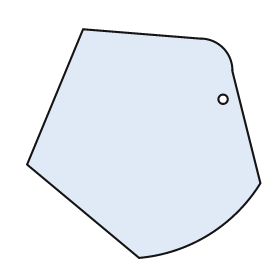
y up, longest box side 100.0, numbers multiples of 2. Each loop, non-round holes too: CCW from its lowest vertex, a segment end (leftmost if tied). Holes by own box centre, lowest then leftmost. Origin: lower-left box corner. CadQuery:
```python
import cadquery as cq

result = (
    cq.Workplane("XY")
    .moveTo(48.0, 0.0)
    .threePointArc((78.0, 10.0), (100.0, 32.0))
    .lineTo(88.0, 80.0)
    .threePointArc((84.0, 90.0), (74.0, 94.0))
    .lineTo(24.0, 98.0)
    .lineTo(0.0, 40.0)
    .close()
    .moveTo(84.0, 68.0)
    .circle(2.0)
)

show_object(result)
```